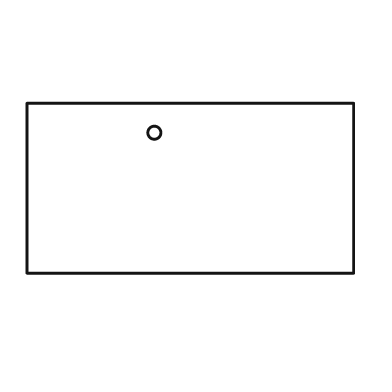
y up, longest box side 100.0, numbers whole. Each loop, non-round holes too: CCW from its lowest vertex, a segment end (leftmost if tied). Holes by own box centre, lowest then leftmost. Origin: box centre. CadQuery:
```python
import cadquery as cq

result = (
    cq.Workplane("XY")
    .moveTo(-50.0, -26.0)
    .lineTo(50.0, -26.0)
    .lineTo(50.0, 26.0)
    .lineTo(-50.0, 26.0)
    .close()
    .moveTo(-11.0, 17.0)
    .circle(2.0)
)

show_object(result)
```